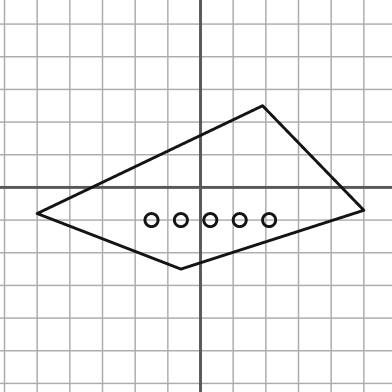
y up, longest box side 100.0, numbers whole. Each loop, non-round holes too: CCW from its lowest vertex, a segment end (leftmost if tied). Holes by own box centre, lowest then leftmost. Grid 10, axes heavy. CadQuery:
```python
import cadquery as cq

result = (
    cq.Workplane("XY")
    .moveTo(-6.0, -25.0)
    .lineTo(50.0, -7.0)
    .lineTo(19.0, 25.0)
    .lineTo(-50.0, -8.0)
    .close()
    .moveTo(-15.0, -10.0)
    .circle(2.0)
    .moveTo(-6.0, -10.0)
    .circle(2.0)
    .moveTo(3.0, -10.0)
    .circle(2.0)
    .moveTo(12.0, -10.0)
    .circle(2.0)
    .moveTo(21.0, -10.0)
    .circle(2.0)
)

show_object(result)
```